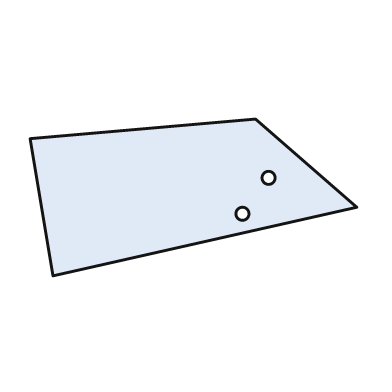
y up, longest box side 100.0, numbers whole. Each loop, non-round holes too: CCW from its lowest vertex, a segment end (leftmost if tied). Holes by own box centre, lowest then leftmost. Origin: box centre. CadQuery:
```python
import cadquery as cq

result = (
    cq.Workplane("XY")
    .moveTo(-43.0, -24.0)
    .lineTo(50.0, -3.0)
    .lineTo(19.0, 24.0)
    .lineTo(-50.0, 18.0)
    .close()
    .moveTo(15.0, -5.0)
    .circle(2.0)
    .moveTo(23.0, 6.0)
    .circle(2.0)
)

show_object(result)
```